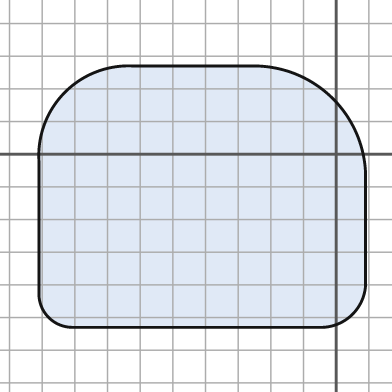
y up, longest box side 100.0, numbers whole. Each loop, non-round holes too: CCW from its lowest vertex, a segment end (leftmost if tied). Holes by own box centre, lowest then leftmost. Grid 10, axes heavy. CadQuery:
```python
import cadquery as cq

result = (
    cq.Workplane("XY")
    .moveTo(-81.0, -53.0)
    .lineTo(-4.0, -53.0)
    .threePointArc((5.0, -49.0), (9.0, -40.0))
    .lineTo(9.0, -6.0)
    .threePointArc((-1.0, 17.0), (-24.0, 27.0))
    .lineTo(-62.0, 27.0)
    .threePointArc((-83.0, 19.0), (-91.0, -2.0))
    .lineTo(-91.0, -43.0)
    .threePointArc((-88.0, -50.0), (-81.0, -53.0))
    .close()
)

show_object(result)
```